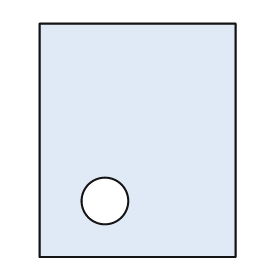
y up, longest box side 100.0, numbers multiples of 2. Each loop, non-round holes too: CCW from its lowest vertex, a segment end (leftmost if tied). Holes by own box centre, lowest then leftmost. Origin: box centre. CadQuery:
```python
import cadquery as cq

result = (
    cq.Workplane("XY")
    .moveTo(-42.0, -50.0)
    .lineTo(42.0, -50.0)
    .lineTo(42.0, 50.0)
    .lineTo(-42.0, 50.0)
    .close()
    .moveTo(-14.0, -26.0)
    .circle(10.0)
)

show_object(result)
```